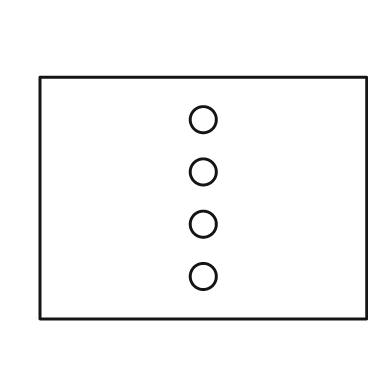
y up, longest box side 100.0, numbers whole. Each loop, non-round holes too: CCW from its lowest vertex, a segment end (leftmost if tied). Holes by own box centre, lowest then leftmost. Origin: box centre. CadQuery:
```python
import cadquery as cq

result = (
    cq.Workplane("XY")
    .moveTo(-50.0, -37.0)
    .lineTo(50.0, -37.0)
    .lineTo(50.0, 37.0)
    .lineTo(-50.0, 37.0)
    .close()
    .moveTo(0.0, -24.0)
    .circle(4.0)
    .moveTo(0.0, -8.0)
    .circle(4.0)
    .moveTo(0.0, 8.0)
    .circle(4.0)
    .moveTo(0.0, 24.0)
    .circle(4.0)
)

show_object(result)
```